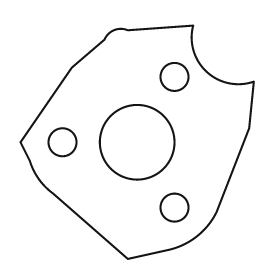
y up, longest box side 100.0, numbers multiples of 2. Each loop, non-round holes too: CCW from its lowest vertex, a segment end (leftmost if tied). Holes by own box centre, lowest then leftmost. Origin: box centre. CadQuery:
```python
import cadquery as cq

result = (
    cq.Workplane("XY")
    .moveTo(-4.0, -50.0)
    .lineTo(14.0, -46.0)
    .threePointArc((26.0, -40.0), (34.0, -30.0))
    .lineTo(48.0, 6.0)
    .lineTo(50.0, 26.0)
    .threePointArc((30.0, 30.0), (24.0, 50.0))
    .lineTo(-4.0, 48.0)
    .threePointArc((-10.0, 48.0), (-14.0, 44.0))
    .lineTo(-28.0, 32.0)
    .lineTo(-50.0, 0.0)
    .lineTo(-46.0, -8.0)
    .threePointArc((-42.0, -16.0), (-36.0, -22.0))
    .close()
    .moveTo(16.0, -28.0)
    .circle(6.0)
    .moveTo(-32.0, 0.0)
    .circle(6.0)
    .moveTo(0.0, 0.0)
    .circle(16.0)
    .moveTo(16.0, 28.0)
    .circle(6.0)
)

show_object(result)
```